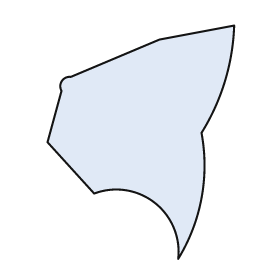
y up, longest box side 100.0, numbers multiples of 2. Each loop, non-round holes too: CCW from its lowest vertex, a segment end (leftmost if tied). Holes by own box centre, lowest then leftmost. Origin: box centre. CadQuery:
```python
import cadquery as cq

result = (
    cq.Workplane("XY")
    .moveTo(16.0, -50.0)
    .threePointArc((26.0, -24.0), (26.0, 4.0))
    .threePointArc((36.0, 26.0), (40.0, 50.0))
    .lineTo(8.0, 44.0)
    .lineTo(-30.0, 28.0)
    .threePointArc((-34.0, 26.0), (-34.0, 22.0))
    .lineTo(-40.0, 0.0)
    .lineTo(-20.0, -22.0)
    .threePointArc((6.0, -26.0), (16.0, -50.0))
    .close()
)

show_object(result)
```